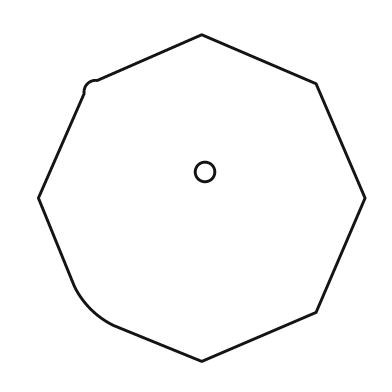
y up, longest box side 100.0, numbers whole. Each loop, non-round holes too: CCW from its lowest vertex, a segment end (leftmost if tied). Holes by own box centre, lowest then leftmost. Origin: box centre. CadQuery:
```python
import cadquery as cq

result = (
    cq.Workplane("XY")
    .moveTo(0.0, -50.0)
    .lineTo(35.0, -35.0)
    .lineTo(50.0, 0.0)
    .lineTo(35.0, 35.0)
    .lineTo(0.0, 50.0)
    .lineTo(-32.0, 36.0)
    .threePointArc((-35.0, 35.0), (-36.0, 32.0))
    .lineTo(-50.0, 0.0)
    .lineTo(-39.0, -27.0)
    .threePointArc((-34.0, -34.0), (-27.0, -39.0))
    .close()
    .moveTo(1.0, 8.0)
    .circle(3.0)
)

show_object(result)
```